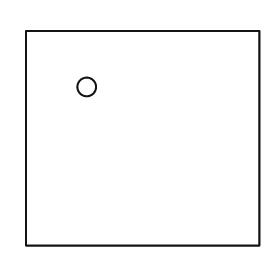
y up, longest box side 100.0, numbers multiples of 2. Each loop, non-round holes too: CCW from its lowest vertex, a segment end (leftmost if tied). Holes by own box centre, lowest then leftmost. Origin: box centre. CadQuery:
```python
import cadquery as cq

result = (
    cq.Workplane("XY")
    .moveTo(-50.0, -46.0)
    .lineTo(50.0, -46.0)
    .lineTo(50.0, 46.0)
    .lineTo(-50.0, 46.0)
    .close()
    .moveTo(-24.0, 22.0)
    .circle(4.0)
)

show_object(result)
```